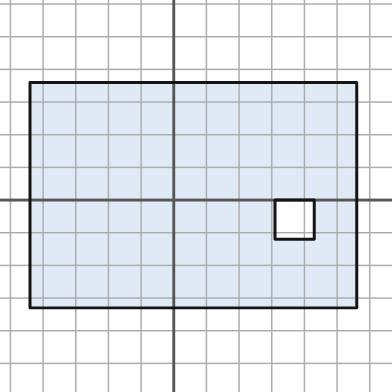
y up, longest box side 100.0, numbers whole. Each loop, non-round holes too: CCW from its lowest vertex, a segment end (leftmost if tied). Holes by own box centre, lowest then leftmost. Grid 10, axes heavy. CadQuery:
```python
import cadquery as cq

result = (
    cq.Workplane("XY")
    .moveTo(-44.0, -33.0)
    .lineTo(56.0, -33.0)
    .lineTo(56.0, 36.0)
    .lineTo(-44.0, 36.0)
    .close()
    .moveTo(31.0, -12.0)
    .lineTo(43.0, -12.0)
    .lineTo(43.0, 0.0)
    .lineTo(31.0, 0.0)
    .close()
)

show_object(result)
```